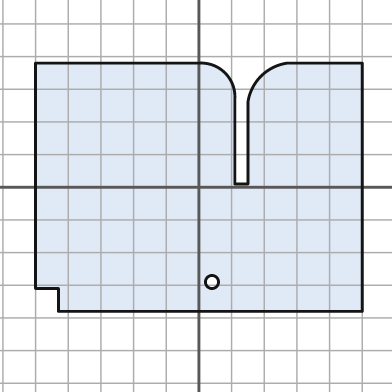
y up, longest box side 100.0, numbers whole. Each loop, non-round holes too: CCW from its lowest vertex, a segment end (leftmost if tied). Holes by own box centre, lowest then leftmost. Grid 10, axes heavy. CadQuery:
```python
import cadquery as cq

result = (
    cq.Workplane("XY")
    .moveTo(-43.0, -38.0)
    .lineTo(50.0, -38.0)
    .lineTo(50.0, 38.0)
    .lineTo(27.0, 38.0)
    .threePointArc((19.0, 34.0), (15.0, 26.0))
    .lineTo(15.0, 1.0)
    .lineTo(11.0, 1.0)
    .lineTo(11.0, 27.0)
    .threePointArc((8.0, 35.0), (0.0, 38.0))
    .lineTo(-50.0, 38.0)
    .lineTo(-50.0, -31.0)
    .lineTo(-43.0, -31.0)
    .close()
    .moveTo(4.0, -29.0)
    .circle(2.0)
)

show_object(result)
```